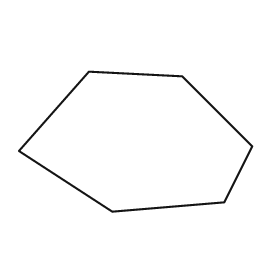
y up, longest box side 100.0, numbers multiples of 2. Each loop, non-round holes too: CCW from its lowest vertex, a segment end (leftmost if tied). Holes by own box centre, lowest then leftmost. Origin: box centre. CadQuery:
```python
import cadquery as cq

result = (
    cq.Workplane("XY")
    .moveTo(-10.0, -30.0)
    .lineTo(38.0, -26.0)
    .lineTo(50.0, -2.0)
    .lineTo(20.0, 28.0)
    .lineTo(-20.0, 30.0)
    .lineTo(-50.0, -4.0)
    .close()
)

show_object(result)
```